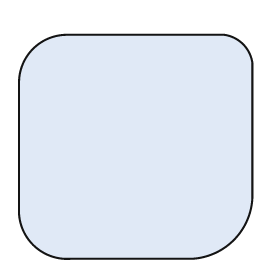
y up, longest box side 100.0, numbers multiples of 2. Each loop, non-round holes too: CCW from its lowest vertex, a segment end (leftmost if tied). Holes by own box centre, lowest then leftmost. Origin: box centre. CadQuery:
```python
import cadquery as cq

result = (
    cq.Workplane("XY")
    .moveTo(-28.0, -48.0)
    .lineTo(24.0, -48.0)
    .threePointArc((42.0, -40.0), (50.0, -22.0))
    .lineTo(50.0, 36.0)
    .threePointArc((46.0, 44.0), (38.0, 48.0))
    .lineTo(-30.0, 48.0)
    .threePointArc((-44.0, 42.0), (-50.0, 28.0))
    .lineTo(-50.0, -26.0)
    .threePointArc((-44.0, -42.0), (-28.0, -48.0))
    .close()
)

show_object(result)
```